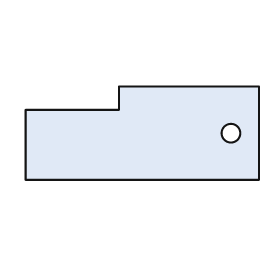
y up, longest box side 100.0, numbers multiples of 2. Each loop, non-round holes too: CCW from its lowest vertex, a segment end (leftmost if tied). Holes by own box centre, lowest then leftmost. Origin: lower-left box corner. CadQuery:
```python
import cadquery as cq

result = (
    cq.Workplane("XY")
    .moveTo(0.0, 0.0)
    .lineTo(100.0, 0.0)
    .lineTo(100.0, 40.0)
    .lineTo(40.0, 40.0)
    .lineTo(40.0, 30.0)
    .lineTo(0.0, 30.0)
    .close()
    .moveTo(88.0, 20.0)
    .circle(4.0)
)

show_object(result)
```